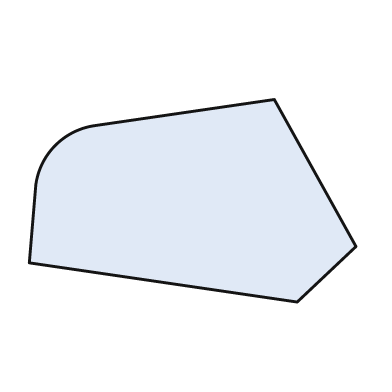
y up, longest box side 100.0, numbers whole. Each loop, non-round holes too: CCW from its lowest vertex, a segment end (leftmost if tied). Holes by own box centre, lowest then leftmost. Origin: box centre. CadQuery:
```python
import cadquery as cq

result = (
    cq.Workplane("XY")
    .moveTo(32.0, -31.0)
    .lineTo(50.0, -14.0)
    .lineTo(25.0, 31.0)
    .lineTo(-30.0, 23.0)
    .threePointArc((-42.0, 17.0), (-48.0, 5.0))
    .lineTo(-50.0, -19.0)
    .close()
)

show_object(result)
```